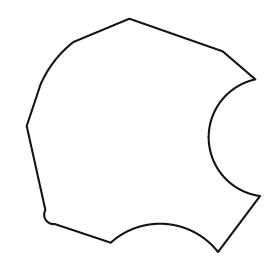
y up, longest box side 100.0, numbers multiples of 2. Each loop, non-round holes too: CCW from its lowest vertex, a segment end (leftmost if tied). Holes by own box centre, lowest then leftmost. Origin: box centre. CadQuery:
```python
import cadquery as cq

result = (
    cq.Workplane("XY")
    .moveTo(32.0, -50.0)
    .lineTo(50.0, -26.0)
    .threePointArc((28.0, -2.0), (48.0, 24.0))
    .lineTo(34.0, 36.0)
    .lineTo(-6.0, 50.0)
    .lineTo(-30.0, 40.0)
    .threePointArc((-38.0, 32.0), (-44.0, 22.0))
    .lineTo(-50.0, 4.0)
    .lineTo(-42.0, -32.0)
    .threePointArc((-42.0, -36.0), (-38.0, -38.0))
    .lineTo(-14.0, -46.0)
    .threePointArc((10.0, -38.0), (32.0, -50.0))
    .close()
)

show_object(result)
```